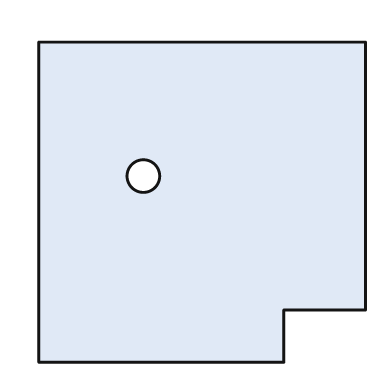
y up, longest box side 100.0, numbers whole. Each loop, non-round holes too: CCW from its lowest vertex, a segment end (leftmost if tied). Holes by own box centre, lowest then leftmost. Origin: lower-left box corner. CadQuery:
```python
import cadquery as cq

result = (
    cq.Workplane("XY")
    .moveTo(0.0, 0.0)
    .lineTo(75.0, 0.0)
    .lineTo(75.0, 16.0)
    .lineTo(100.0, 16.0)
    .lineTo(100.0, 98.0)
    .lineTo(0.0, 98.0)
    .close()
    .moveTo(32.0, 57.0)
    .circle(5.0)
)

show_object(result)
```